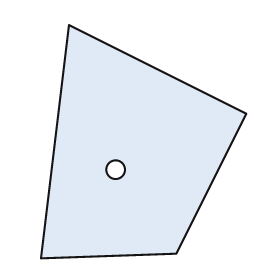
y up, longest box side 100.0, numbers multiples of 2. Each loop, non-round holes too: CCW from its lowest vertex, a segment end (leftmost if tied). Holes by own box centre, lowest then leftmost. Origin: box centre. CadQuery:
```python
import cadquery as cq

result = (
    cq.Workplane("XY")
    .moveTo(-44.0, -50.0)
    .lineTo(14.0, -48.0)
    .lineTo(44.0, 12.0)
    .lineTo(-32.0, 50.0)
    .close()
    .moveTo(-12.0, -12.0)
    .circle(4.0)
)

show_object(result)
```